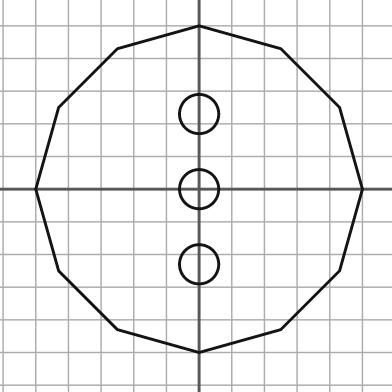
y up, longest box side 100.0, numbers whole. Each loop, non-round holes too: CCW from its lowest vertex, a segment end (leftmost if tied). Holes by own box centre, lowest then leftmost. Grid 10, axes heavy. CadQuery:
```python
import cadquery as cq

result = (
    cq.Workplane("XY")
    .moveTo(0.0, -50.0)
    .lineTo(25.0, -43.0)
    .lineTo(43.0, -25.0)
    .lineTo(50.0, 0.0)
    .lineTo(43.0, 25.0)
    .lineTo(25.0, 43.0)
    .lineTo(0.0, 50.0)
    .lineTo(-25.0, 43.0)
    .lineTo(-43.0, 25.0)
    .lineTo(-50.0, 0.0)
    .lineTo(-43.0, -25.0)
    .lineTo(-25.0, -43.0)
    .close()
    .moveTo(0.0, -23.0)
    .circle(6.0)
    .moveTo(0.0, 0.0)
    .circle(6.0)
    .moveTo(0.0, 23.0)
    .circle(6.0)
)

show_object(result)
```